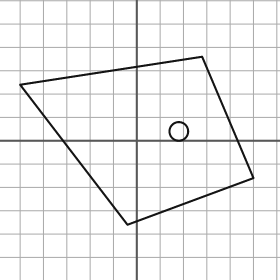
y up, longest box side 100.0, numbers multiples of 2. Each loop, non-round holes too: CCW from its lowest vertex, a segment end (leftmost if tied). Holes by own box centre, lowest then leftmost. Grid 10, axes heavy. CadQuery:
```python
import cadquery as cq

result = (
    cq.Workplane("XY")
    .moveTo(-4.0, -36.0)
    .lineTo(50.0, -16.0)
    .lineTo(28.0, 36.0)
    .lineTo(-50.0, 24.0)
    .close()
    .moveTo(18.0, 4.0)
    .circle(4.0)
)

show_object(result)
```